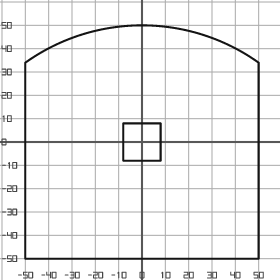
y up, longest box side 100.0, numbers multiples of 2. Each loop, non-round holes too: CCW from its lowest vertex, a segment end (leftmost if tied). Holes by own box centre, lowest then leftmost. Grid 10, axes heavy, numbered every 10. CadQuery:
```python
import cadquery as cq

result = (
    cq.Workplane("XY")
    .moveTo(-50.0, -50.0)
    .lineTo(50.0, -50.0)
    .lineTo(50.0, 34.0)
    .threePointArc((0.0, 50.0), (-50.0, 34.0))
    .close()
    .moveTo(-8.0, -8.0)
    .lineTo(8.0, -8.0)
    .lineTo(8.0, 8.0)
    .lineTo(-8.0, 8.0)
    .close()
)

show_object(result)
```